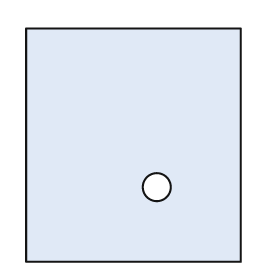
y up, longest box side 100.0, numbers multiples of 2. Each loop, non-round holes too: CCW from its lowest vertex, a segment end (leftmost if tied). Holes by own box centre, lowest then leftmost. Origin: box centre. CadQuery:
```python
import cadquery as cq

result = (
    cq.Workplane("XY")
    .moveTo(-46.0, -50.0)
    .lineTo(46.0, -50.0)
    .lineTo(46.0, 50.0)
    .lineTo(-46.0, 50.0)
    .close()
    .moveTo(10.0, -18.0)
    .circle(6.0)
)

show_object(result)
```